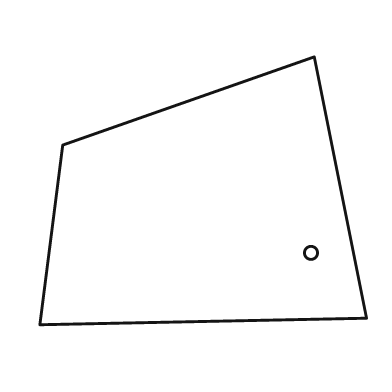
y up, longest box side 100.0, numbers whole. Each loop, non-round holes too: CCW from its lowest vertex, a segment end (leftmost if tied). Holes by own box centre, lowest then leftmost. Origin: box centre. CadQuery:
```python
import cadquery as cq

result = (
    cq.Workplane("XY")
    .moveTo(-50.0, -41.0)
    .lineTo(50.0, -39.0)
    .lineTo(34.0, 41.0)
    .lineTo(-43.0, 14.0)
    .close()
    .moveTo(33.0, -19.0)
    .circle(2.0)
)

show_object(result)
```